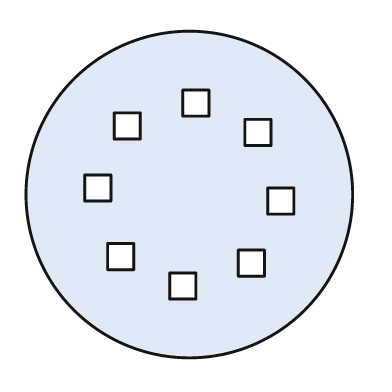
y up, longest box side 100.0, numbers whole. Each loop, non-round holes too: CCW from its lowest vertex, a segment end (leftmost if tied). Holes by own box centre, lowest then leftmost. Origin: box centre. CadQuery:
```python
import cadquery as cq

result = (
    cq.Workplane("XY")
    .moveTo(0.0, 0.0)
    .circle(50.0)
    .moveTo(-6.0, -32.0)
    .lineTo(2.0, -32.0)
    .lineTo(2.0, -24.0)
    .lineTo(-6.0, -24.0)
    .close()
    .moveTo(15.0, -25.0)
    .lineTo(23.0, -25.0)
    .lineTo(23.0, -17.0)
    .lineTo(15.0, -17.0)
    .close()
    .moveTo(-25.0, -23.0)
    .lineTo(-17.0, -23.0)
    .lineTo(-17.0, -15.0)
    .lineTo(-25.0, -15.0)
    .close()
    .moveTo(24.0, -6.0)
    .lineTo(32.0, -6.0)
    .lineTo(32.0, 2.0)
    .lineTo(24.0, 2.0)
    .close()
    .moveTo(-32.0, -2.0)
    .lineTo(-24.0, -2.0)
    .lineTo(-24.0, 6.0)
    .lineTo(-32.0, 6.0)
    .close()
    .moveTo(17.0, 15.0)
    .lineTo(25.0, 15.0)
    .lineTo(25.0, 23.0)
    .lineTo(17.0, 23.0)
    .close()
    .moveTo(-23.0, 17.0)
    .lineTo(-15.0, 17.0)
    .lineTo(-15.0, 25.0)
    .lineTo(-23.0, 25.0)
    .close()
    .moveTo(-2.0, 24.0)
    .lineTo(6.0, 24.0)
    .lineTo(6.0, 32.0)
    .lineTo(-2.0, 32.0)
    .close()
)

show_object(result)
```